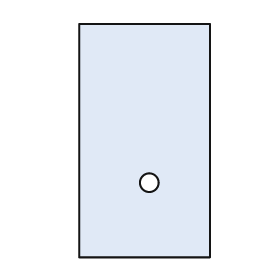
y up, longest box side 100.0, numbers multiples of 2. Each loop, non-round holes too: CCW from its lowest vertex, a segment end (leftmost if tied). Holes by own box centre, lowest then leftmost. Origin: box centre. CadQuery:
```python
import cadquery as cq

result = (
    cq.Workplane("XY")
    .moveTo(-28.0, -50.0)
    .lineTo(28.0, -50.0)
    .lineTo(28.0, 50.0)
    .lineTo(-28.0, 50.0)
    .close()
    .moveTo(2.0, -18.0)
    .circle(4.0)
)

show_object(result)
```